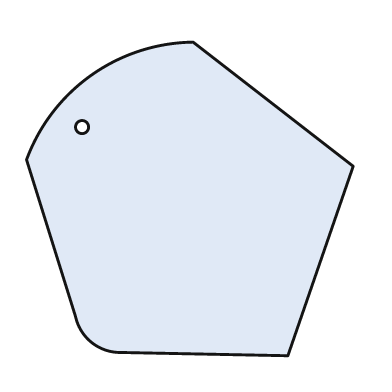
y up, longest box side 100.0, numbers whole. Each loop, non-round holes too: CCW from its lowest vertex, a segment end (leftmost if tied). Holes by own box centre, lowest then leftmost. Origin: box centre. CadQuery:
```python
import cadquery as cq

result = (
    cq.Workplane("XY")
    .moveTo(30.0, -48.0)
    .lineTo(50.0, 10.0)
    .lineTo(1.0, 48.0)
    .threePointArc((-30.0, 38.0), (-50.0, 12.0))
    .lineTo(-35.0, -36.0)
    .threePointArc((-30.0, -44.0), (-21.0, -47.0))
    .close()
    .moveTo(-33.0, 22.0)
    .circle(2.0)
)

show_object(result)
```